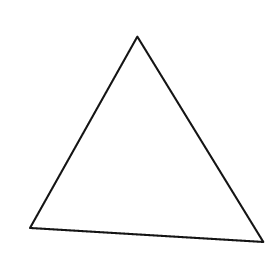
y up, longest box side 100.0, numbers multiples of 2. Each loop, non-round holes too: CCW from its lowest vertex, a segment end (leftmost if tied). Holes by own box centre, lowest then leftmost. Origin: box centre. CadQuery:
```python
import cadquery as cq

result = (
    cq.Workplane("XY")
    .moveTo(50.0, -44.0)
    .lineTo(-4.0, 44.0)
    .lineTo(-50.0, -38.0)
    .close()
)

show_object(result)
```